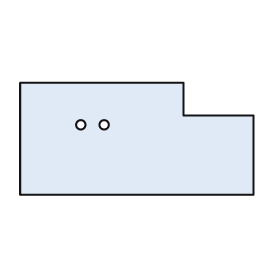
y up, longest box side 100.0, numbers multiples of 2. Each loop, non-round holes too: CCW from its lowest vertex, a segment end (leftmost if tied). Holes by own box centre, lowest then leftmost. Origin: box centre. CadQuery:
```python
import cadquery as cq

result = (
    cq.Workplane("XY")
    .moveTo(-50.0, -24.0)
    .lineTo(50.0, -24.0)
    .lineTo(50.0, 10.0)
    .lineTo(20.0, 10.0)
    .lineTo(20.0, 24.0)
    .lineTo(-50.0, 24.0)
    .close()
    .moveTo(-24.0, 6.0)
    .circle(2.0)
    .moveTo(-14.0, 6.0)
    .circle(2.0)
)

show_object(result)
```